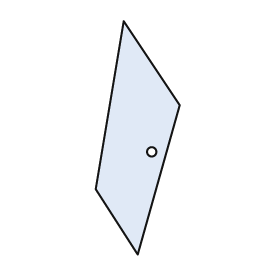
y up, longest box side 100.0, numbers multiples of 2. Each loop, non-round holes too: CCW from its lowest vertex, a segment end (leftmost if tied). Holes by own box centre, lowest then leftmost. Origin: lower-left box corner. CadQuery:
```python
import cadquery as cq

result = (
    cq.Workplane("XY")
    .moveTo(18.0, 0.0)
    .lineTo(36.0, 64.0)
    .lineTo(12.0, 100.0)
    .lineTo(0.0, 28.0)
    .close()
    .moveTo(24.0, 44.0)
    .circle(2.0)
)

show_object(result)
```